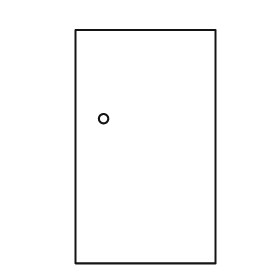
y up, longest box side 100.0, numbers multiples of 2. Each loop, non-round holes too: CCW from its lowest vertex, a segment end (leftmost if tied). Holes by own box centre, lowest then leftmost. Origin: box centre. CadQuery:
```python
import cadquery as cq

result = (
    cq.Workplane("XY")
    .moveTo(-30.0, -50.0)
    .lineTo(30.0, -50.0)
    .lineTo(30.0, 50.0)
    .lineTo(-30.0, 50.0)
    .close()
    .moveTo(-18.0, 12.0)
    .circle(2.0)
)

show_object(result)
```